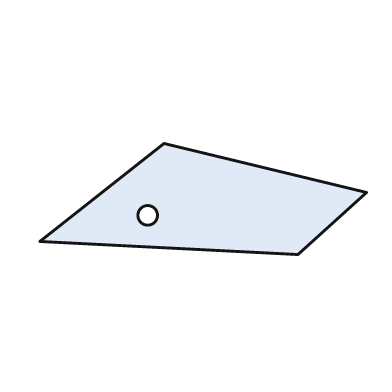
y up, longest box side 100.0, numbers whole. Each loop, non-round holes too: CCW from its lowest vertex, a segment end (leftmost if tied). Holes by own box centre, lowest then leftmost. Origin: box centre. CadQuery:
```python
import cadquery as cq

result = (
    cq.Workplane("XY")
    .moveTo(29.0, -17.0)
    .lineTo(50.0, 2.0)
    .lineTo(-12.0, 17.0)
    .lineTo(-50.0, -13.0)
    .close()
    .moveTo(-17.0, -5.0)
    .circle(3.0)
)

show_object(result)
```